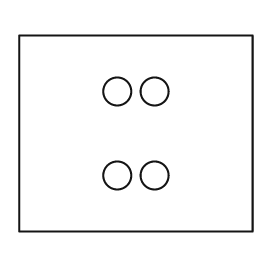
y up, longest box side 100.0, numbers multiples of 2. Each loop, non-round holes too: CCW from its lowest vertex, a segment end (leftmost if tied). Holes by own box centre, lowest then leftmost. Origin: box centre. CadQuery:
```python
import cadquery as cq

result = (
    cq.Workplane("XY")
    .moveTo(-50.0, -42.0)
    .lineTo(50.0, -42.0)
    .lineTo(50.0, 42.0)
    .lineTo(-50.0, 42.0)
    .close()
    .moveTo(-8.0, -18.0)
    .circle(6.0)
    .moveTo(8.0, -18.0)
    .circle(6.0)
    .moveTo(-8.0, 18.0)
    .circle(6.0)
    .moveTo(8.0, 18.0)
    .circle(6.0)
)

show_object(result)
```